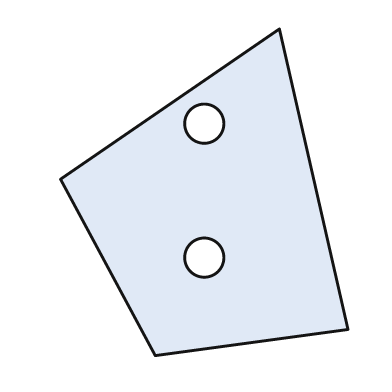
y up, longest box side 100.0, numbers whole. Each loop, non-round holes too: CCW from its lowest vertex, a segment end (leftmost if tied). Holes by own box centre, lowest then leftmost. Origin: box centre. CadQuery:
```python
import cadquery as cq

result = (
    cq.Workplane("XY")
    .moveTo(-15.0, -50.0)
    .lineTo(44.0, -42.0)
    .lineTo(23.0, 50.0)
    .lineTo(-44.0, 4.0)
    .close()
    .moveTo(0.0, -20.0)
    .circle(6.0)
    .moveTo(0.0, 21.0)
    .circle(6.0)
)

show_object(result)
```